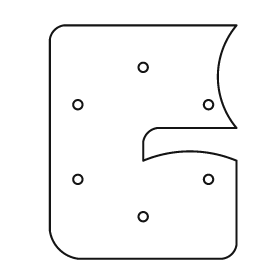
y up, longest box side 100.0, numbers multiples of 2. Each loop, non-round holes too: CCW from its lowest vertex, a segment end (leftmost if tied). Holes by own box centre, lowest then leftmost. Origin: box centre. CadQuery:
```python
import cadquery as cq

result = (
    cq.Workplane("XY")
    .moveTo(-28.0, -50.0)
    .lineTo(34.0, -50.0)
    .threePointArc((38.0, -48.0), (40.0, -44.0))
    .lineTo(40.0, -8.0)
    .threePointArc((20.0, -4.0), (0.0, -8.0))
    .lineTo(0.0, 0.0)
    .threePointArc((2.0, 4.0), (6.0, 6.0))
    .lineTo(40.0, 6.0)
    .threePointArc((32.0, 28.0), (40.0, 50.0))
    .lineTo(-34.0, 50.0)
    .threePointArc((-38.0, 48.0), (-40.0, 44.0))
    .lineTo(-40.0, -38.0)
    .threePointArc((-36.0, -46.0), (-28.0, -50.0))
    .close()
    .moveTo(0.0, -32.0)
    .circle(2.0)
    .moveTo(-28.0, -16.0)
    .circle(2.0)
    .moveTo(28.0, -16.0)
    .circle(2.0)
    .moveTo(-28.0, 16.0)
    .circle(2.0)
    .moveTo(28.0, 16.0)
    .circle(2.0)
    .moveTo(0.0, 32.0)
    .circle(2.0)
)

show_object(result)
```